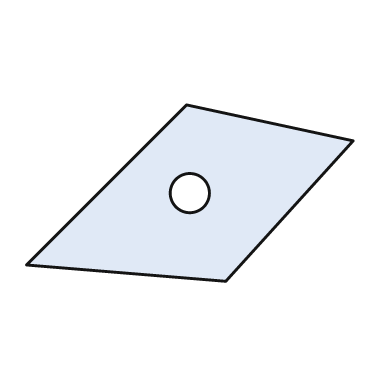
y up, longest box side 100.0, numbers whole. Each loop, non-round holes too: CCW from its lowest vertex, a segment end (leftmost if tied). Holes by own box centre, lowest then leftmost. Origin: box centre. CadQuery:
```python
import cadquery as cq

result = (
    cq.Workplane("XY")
    .moveTo(11.0, -27.0)
    .lineTo(50.0, 16.0)
    .lineTo(-1.0, 27.0)
    .lineTo(-50.0, -22.0)
    .close()
    .moveTo(0.0, 0.0)
    .circle(6.0)
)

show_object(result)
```